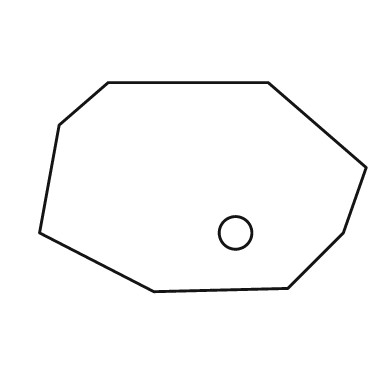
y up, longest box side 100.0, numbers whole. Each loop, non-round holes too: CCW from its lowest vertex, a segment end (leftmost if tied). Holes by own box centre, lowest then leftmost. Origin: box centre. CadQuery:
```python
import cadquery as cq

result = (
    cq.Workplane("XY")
    .moveTo(-15.0, -32.0)
    .lineTo(26.0, -31.0)
    .lineTo(43.0, -14.0)
    .lineTo(50.0, 6.0)
    .lineTo(20.0, 32.0)
    .lineTo(-29.0, 32.0)
    .lineTo(-44.0, 19.0)
    .lineTo(-50.0, -14.0)
    .close()
    .moveTo(10.0, -14.0)
    .circle(5.0)
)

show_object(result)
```